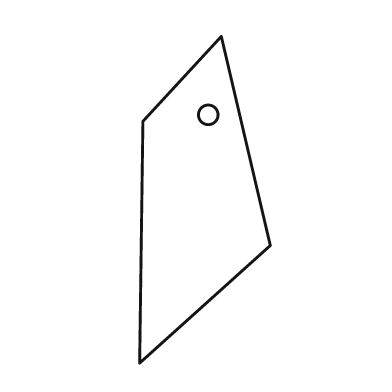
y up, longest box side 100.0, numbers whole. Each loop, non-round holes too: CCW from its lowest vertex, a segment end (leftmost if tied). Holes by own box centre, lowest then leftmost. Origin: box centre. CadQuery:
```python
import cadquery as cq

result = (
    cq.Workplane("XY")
    .moveTo(-20.0, -50.0)
    .lineTo(20.0, -14.0)
    .lineTo(5.0, 50.0)
    .lineTo(-19.0, 24.0)
    .close()
    .moveTo(1.0, 26.0)
    .circle(3.0)
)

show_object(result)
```